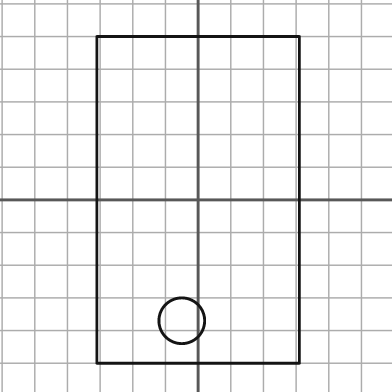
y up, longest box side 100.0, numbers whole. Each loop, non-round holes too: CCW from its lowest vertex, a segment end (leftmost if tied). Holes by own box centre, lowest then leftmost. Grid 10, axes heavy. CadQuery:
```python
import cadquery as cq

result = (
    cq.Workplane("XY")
    .moveTo(-31.0, -50.0)
    .lineTo(31.0, -50.0)
    .lineTo(31.0, 50.0)
    .lineTo(-31.0, 50.0)
    .close()
    .moveTo(-5.0, -37.0)
    .circle(7.0)
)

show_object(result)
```